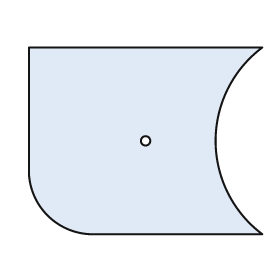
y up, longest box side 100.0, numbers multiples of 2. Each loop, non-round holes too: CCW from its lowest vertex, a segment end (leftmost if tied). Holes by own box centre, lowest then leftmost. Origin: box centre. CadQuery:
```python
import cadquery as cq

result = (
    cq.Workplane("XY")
    .moveTo(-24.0, -40.0)
    .lineTo(50.0, -40.0)
    .threePointArc((30.0, 0.0), (50.0, 40.0))
    .lineTo(-50.0, 40.0)
    .lineTo(-50.0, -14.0)
    .threePointArc((-42.0, -32.0), (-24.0, -40.0))
    .close()
    .moveTo(0.0, 0.0)
    .circle(2.0)
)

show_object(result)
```